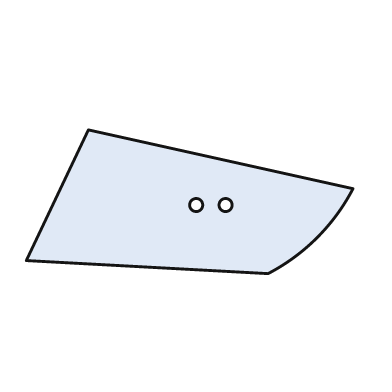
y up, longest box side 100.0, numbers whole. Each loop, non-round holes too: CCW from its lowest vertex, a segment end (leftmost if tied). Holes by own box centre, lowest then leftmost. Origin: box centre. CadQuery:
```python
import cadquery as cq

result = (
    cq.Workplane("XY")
    .moveTo(24.0, -22.0)
    .threePointArc((39.0, -11.0), (50.0, 4.0))
    .lineTo(-31.0, 22.0)
    .lineTo(-50.0, -18.0)
    .close()
    .moveTo(2.0, -1.0)
    .circle(2.0)
    .moveTo(11.0, -1.0)
    .circle(2.0)
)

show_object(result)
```